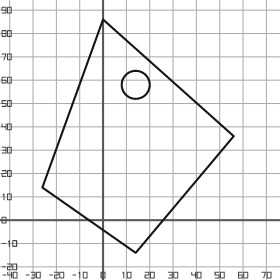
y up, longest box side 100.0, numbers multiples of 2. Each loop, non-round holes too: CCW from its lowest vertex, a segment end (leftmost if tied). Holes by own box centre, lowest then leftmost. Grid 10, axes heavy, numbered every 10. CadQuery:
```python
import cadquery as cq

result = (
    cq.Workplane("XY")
    .moveTo(14.0, -14.0)
    .lineTo(56.0, 36.0)
    .lineTo(0.0, 86.0)
    .lineTo(-26.0, 14.0)
    .close()
    .moveTo(14.0, 58.0)
    .circle(6.0)
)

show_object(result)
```